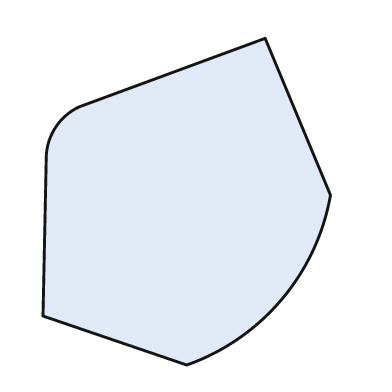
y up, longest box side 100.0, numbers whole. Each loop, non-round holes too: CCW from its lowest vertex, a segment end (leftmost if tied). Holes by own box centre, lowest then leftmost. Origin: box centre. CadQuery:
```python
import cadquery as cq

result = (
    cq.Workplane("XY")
    .moveTo(0.0, -50.0)
    .threePointArc((29.0, -30.0), (44.0, 2.0))
    .lineTo(24.0, 50.0)
    .lineTo(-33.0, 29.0)
    .threePointArc((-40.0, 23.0), (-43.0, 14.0))
    .lineTo(-44.0, -35.0)
    .close()
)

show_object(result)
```